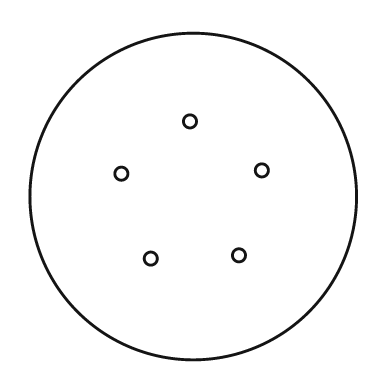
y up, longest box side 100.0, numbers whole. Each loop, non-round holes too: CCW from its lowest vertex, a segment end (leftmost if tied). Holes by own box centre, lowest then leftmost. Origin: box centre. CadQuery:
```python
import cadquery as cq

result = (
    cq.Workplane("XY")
    .moveTo(0.0, 0.0)
    .circle(50.0)
    .moveTo(-13.0, -19.0)
    .circle(2.0)
    .moveTo(14.0, -18.0)
    .circle(2.0)
    .moveTo(-22.0, 7.0)
    .circle(2.0)
    .moveTo(21.0, 8.0)
    .circle(2.0)
    .moveTo(-1.0, 23.0)
    .circle(2.0)
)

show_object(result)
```